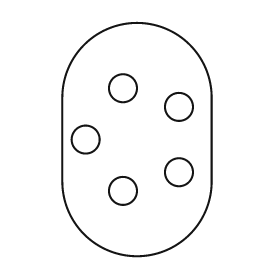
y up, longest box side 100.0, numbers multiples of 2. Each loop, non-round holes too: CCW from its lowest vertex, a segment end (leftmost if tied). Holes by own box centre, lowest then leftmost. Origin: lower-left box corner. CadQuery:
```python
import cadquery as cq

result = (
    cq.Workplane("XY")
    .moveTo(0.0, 32.0)
    .threePointArc((32.0, 0.0), (64.0, 32.0))
    .lineTo(64.0, 68.0)
    .threePointArc((32.0, 100.0), (0.0, 68.0))
    .close()
    .moveTo(26.0, 28.0)
    .circle(6.0)
    .moveTo(50.0, 36.0)
    .circle(6.0)
    .moveTo(10.0, 50.0)
    .circle(6.0)
    .moveTo(50.0, 64.0)
    .circle(6.0)
    .moveTo(26.0, 72.0)
    .circle(6.0)
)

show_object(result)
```